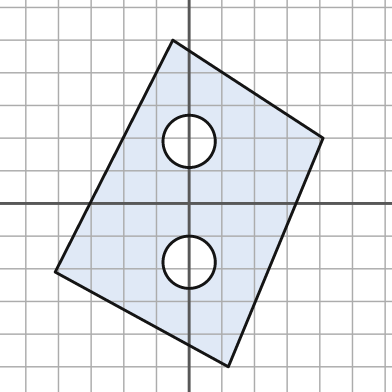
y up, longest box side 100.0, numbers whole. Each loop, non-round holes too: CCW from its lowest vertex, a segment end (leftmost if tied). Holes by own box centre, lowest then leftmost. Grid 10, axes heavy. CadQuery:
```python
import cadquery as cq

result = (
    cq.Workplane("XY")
    .moveTo(12.0, -50.0)
    .lineTo(41.0, 20.0)
    .lineTo(-5.0, 50.0)
    .lineTo(-41.0, -21.0)
    .close()
    .moveTo(0.0, -18.0)
    .circle(8.0)
    .moveTo(0.0, 19.0)
    .circle(8.0)
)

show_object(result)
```